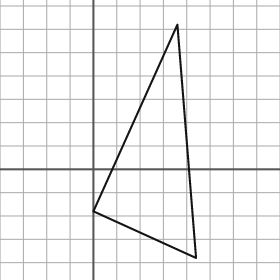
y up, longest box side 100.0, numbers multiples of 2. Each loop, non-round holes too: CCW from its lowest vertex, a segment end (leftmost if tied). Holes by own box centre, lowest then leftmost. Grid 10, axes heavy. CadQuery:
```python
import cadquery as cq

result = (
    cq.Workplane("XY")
    .moveTo(44.0, -38.0)
    .lineTo(36.0, 62.0)
    .lineTo(0.0, -18.0)
    .close()
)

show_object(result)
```